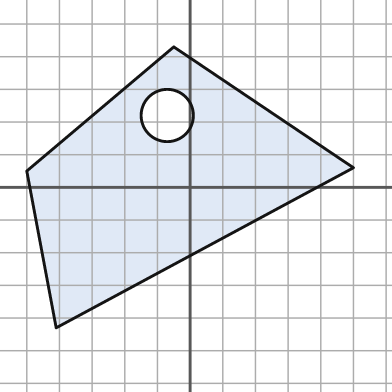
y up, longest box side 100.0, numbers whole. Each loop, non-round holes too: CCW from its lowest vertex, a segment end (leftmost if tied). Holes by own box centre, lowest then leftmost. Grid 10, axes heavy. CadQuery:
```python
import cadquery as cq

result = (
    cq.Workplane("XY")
    .moveTo(-41.0, -43.0)
    .lineTo(50.0, 6.0)
    .lineTo(-5.0, 43.0)
    .lineTo(-50.0, 5.0)
    .close()
    .moveTo(-7.0, 22.0)
    .circle(8.0)
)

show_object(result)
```